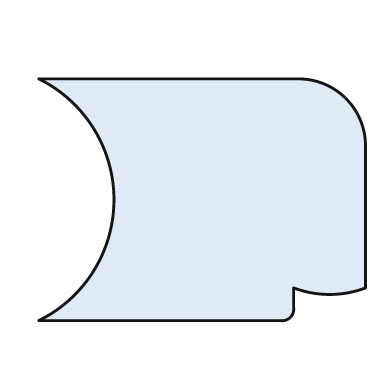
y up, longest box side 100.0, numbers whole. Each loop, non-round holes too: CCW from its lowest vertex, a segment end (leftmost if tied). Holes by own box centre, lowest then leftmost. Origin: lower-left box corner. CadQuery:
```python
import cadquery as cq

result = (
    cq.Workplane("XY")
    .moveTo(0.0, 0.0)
    .lineTo(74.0, 0.0)
    .threePointArc((77.0, 1.0), (78.0, 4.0))
    .lineTo(78.0, 10.0)
    .threePointArc((89.0, 8.0), (100.0, 10.0))
    .lineTo(100.0, 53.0)
    .threePointArc((94.0, 68.0), (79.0, 74.0))
    .lineTo(0.0, 74.0)
    .threePointArc((23.0, 37.0), (0.0, 0.0))
    .close()
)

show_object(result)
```